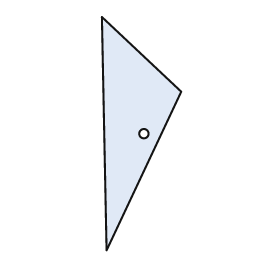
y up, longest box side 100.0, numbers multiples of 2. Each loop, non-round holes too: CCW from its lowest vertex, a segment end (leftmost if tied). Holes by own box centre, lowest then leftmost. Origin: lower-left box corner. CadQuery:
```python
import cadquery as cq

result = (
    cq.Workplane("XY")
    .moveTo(2.0, 0.0)
    .lineTo(34.0, 68.0)
    .lineTo(0.0, 100.0)
    .close()
    .moveTo(18.0, 50.0)
    .circle(2.0)
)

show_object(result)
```